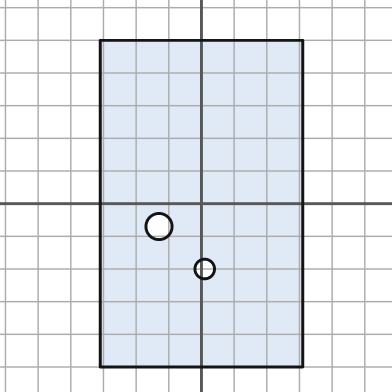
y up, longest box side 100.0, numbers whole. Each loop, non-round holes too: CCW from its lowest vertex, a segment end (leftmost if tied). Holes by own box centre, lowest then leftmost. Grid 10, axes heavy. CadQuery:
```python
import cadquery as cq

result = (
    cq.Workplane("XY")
    .moveTo(-31.0, -50.0)
    .lineTo(31.0, -50.0)
    .lineTo(31.0, 50.0)
    .lineTo(-31.0, 50.0)
    .close()
    .moveTo(1.0, -20.0)
    .circle(3.0)
    .moveTo(-13.0, -7.0)
    .circle(4.0)
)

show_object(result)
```